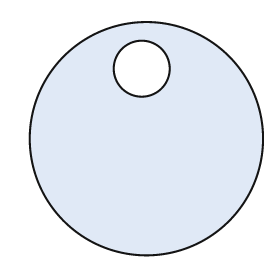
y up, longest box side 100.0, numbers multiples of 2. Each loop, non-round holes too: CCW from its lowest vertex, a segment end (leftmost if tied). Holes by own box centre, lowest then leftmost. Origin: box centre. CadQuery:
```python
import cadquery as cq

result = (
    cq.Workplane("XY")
    .moveTo(0.0, 0.0)
    .circle(50.0)
    .moveTo(-2.0, 30.0)
    .circle(12.0)
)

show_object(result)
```